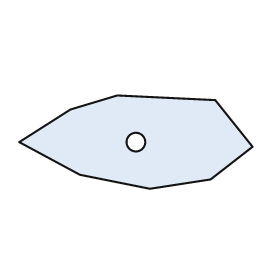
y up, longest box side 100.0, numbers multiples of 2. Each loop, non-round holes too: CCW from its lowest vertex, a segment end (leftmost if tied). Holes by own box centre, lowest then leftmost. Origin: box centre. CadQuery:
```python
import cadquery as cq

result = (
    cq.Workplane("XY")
    .moveTo(6.0, -20.0)
    .lineTo(32.0, -16.0)
    .lineTo(50.0, -2.0)
    .lineTo(34.0, 18.0)
    .lineTo(-8.0, 20.0)
    .lineTo(-28.0, 14.0)
    .lineTo(-50.0, 0.0)
    .lineTo(-24.0, -14.0)
    .close()
    .moveTo(0.0, 0.0)
    .circle(4.0)
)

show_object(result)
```